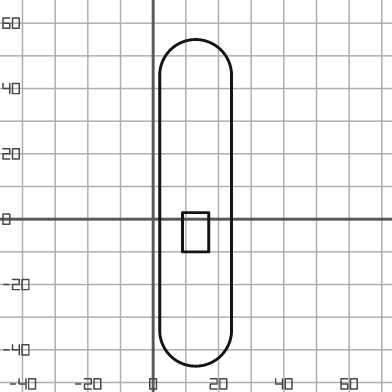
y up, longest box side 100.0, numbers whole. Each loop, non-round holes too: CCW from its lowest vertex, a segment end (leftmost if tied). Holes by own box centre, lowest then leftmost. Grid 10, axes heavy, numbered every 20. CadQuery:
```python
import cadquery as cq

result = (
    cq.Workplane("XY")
    .moveTo(2.0, -34.0)
    .threePointArc((13.0, -45.0), (24.0, -34.0))
    .lineTo(24.0, 44.0)
    .threePointArc((13.0, 55.0), (2.0, 44.0))
    .close()
    .moveTo(9.0, -10.0)
    .lineTo(17.0, -10.0)
    .lineTo(17.0, 2.0)
    .lineTo(9.0, 2.0)
    .close()
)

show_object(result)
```